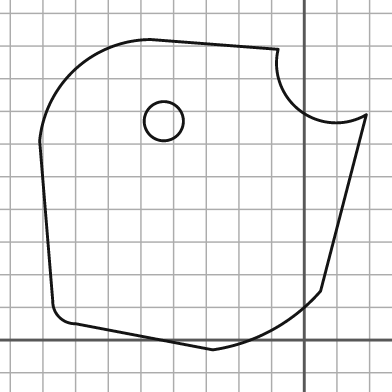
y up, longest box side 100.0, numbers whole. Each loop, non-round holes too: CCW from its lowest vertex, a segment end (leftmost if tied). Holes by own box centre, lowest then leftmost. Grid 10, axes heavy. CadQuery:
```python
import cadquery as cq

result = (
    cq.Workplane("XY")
    .moveTo(-28.0, -3.0)
    .threePointArc((-10.0, 3.0), (5.0, 15.0))
    .lineTo(19.0, 69.0)
    .threePointArc((-1.0, 70.0), (-8.0, 89.0))
    .lineTo(-47.0, 92.0)
    .threePointArc((-70.0, 83.0), (-81.0, 61.0))
    .lineTo(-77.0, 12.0)
    .threePointArc((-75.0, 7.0), (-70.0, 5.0))
    .close()
    .moveTo(-43.0, 67.0)
    .circle(6.0)
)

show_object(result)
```